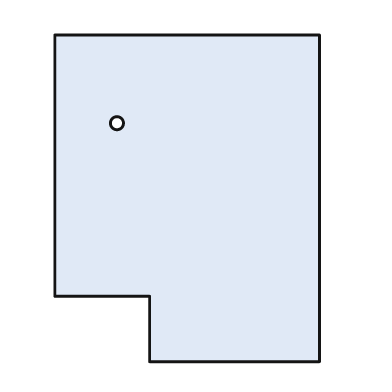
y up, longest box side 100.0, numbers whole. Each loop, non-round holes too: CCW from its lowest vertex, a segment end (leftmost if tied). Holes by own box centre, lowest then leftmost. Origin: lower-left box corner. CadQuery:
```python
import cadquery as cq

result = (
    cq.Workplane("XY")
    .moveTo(29.0, 0.0)
    .lineTo(81.0, 0.0)
    .lineTo(81.0, 100.0)
    .lineTo(0.0, 100.0)
    .lineTo(0.0, 20.0)
    .lineTo(29.0, 20.0)
    .close()
    .moveTo(19.0, 73.0)
    .circle(2.0)
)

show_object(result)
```